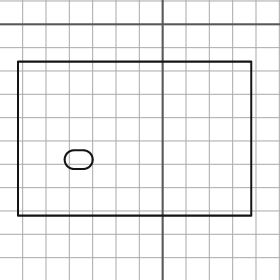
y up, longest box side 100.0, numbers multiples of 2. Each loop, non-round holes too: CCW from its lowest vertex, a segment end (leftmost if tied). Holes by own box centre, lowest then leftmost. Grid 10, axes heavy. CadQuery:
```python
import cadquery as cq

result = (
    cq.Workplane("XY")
    .moveTo(-62.0, -82.0)
    .lineTo(38.0, -82.0)
    .lineTo(38.0, -16.0)
    .lineTo(-62.0, -16.0)
    .close()
    .moveTo(-38.0, -62.0)
    .lineTo(-34.0, -62.0)
    .threePointArc((-30.0, -58.0), (-34.0, -54.0))
    .lineTo(-38.0, -54.0)
    .threePointArc((-42.0, -58.0), (-38.0, -62.0))
    .close()
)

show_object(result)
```